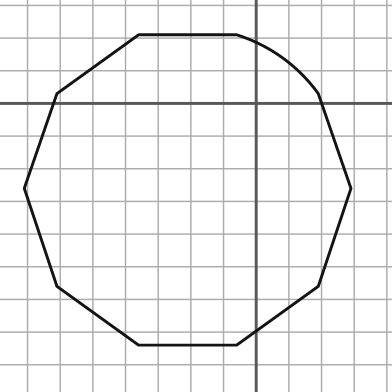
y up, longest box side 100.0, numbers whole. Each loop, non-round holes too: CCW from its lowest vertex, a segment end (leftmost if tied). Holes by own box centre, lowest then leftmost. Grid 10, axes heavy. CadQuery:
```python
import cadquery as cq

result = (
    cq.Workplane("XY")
    .moveTo(-36.0, -74.0)
    .lineTo(-6.0, -74.0)
    .lineTo(19.0, -56.0)
    .lineTo(29.0, -26.0)
    .lineTo(19.0, 3.0)
    .threePointArc((8.0, 14.0), (-6.0, 21.0))
    .lineTo(-36.0, 21.0)
    .lineTo(-61.0, 3.0)
    .lineTo(-71.0, -26.0)
    .lineTo(-61.0, -56.0)
    .close()
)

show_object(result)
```